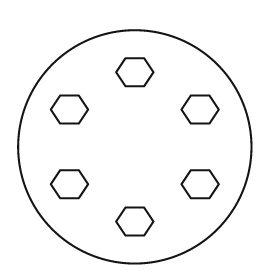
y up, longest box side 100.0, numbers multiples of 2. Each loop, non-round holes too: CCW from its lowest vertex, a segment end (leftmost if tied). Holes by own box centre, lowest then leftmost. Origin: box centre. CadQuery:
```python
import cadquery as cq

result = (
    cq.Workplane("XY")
    .moveTo(0.0, 0.0)
    .circle(50.0)
    .moveTo(-4.0, -38.0)
    .lineTo(4.0, -38.0)
    .lineTo(8.0, -32.0)
    .lineTo(4.0, -26.0)
    .lineTo(-4.0, -26.0)
    .lineTo(-8.0, -32.0)
    .close()
    .moveTo(-32.0, -22.0)
    .lineTo(-24.0, -22.0)
    .lineTo(-20.0, -16.0)
    .lineTo(-24.0, -10.0)
    .lineTo(-32.0, -10.0)
    .lineTo(-36.0, -16.0)
    .close()
    .moveTo(24.0, -22.0)
    .lineTo(32.0, -22.0)
    .lineTo(36.0, -16.0)
    .lineTo(32.0, -10.0)
    .lineTo(24.0, -10.0)
    .lineTo(20.0, -16.0)
    .close()
    .moveTo(-32.0, 10.0)
    .lineTo(-24.0, 10.0)
    .lineTo(-20.0, 16.0)
    .lineTo(-24.0, 22.0)
    .lineTo(-32.0, 22.0)
    .lineTo(-36.0, 16.0)
    .close()
    .moveTo(24.0, 10.0)
    .lineTo(32.0, 10.0)
    .lineTo(36.0, 16.0)
    .lineTo(32.0, 22.0)
    .lineTo(24.0, 22.0)
    .lineTo(20.0, 16.0)
    .close()
    .moveTo(-4.0, 26.0)
    .lineTo(4.0, 26.0)
    .lineTo(8.0, 32.0)
    .lineTo(4.0, 38.0)
    .lineTo(-4.0, 38.0)
    .lineTo(-8.0, 32.0)
    .close()
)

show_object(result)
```